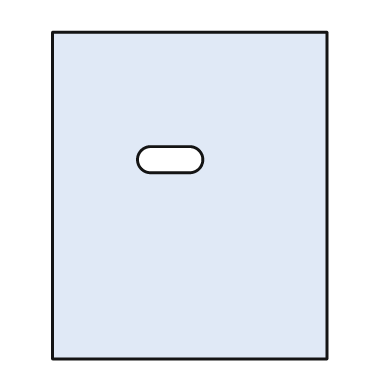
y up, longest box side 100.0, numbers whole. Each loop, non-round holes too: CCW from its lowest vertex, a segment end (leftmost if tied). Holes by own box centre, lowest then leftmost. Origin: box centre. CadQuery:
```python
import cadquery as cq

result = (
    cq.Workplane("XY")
    .moveTo(-42.0, -50.0)
    .lineTo(42.0, -50.0)
    .lineTo(42.0, 50.0)
    .lineTo(-42.0, 50.0)
    .close()
    .moveTo(-12.0, 7.0)
    .lineTo(0.0, 7.0)
    .threePointArc((4.0, 11.0), (0.0, 15.0))
    .lineTo(-12.0, 15.0)
    .threePointArc((-16.0, 11.0), (-12.0, 7.0))
    .close()
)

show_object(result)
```